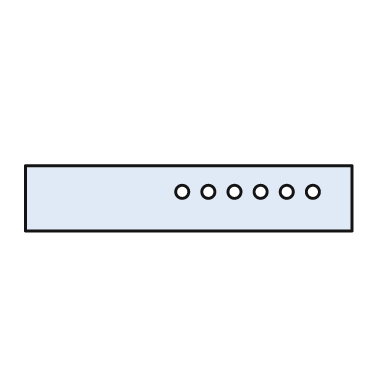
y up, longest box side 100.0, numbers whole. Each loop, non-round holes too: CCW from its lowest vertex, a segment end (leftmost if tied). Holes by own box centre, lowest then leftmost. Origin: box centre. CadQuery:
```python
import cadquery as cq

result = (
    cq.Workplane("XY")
    .moveTo(-50.0, -10.0)
    .lineTo(50.0, -10.0)
    .lineTo(50.0, 10.0)
    .lineTo(-50.0, 10.0)
    .close()
    .moveTo(-2.0, 2.0)
    .circle(2.0)
    .moveTo(6.0, 2.0)
    .circle(2.0)
    .moveTo(14.0, 2.0)
    .circle(2.0)
    .moveTo(22.0, 2.0)
    .circle(2.0)
    .moveTo(30.0, 2.0)
    .circle(2.0)
    .moveTo(38.0, 2.0)
    .circle(2.0)
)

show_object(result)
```